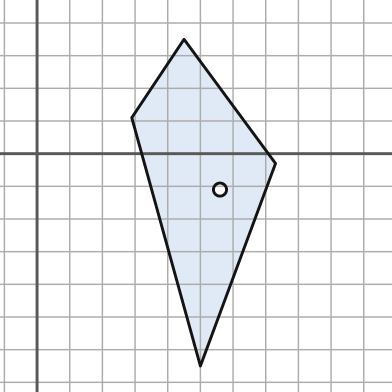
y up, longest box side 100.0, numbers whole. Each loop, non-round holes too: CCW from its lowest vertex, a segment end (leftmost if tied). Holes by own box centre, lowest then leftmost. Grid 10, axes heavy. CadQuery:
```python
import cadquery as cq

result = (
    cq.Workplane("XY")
    .moveTo(50.0, -65.0)
    .lineTo(73.0, -3.0)
    .lineTo(45.0, 35.0)
    .lineTo(29.0, 11.0)
    .close()
    .moveTo(56.0, -11.0)
    .circle(2.0)
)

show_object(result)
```